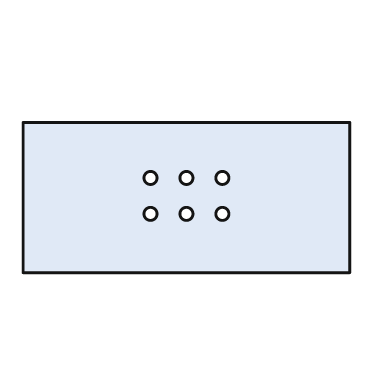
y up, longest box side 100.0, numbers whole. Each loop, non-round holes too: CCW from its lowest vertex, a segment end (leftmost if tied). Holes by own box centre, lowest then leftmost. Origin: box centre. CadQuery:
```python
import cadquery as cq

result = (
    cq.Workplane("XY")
    .moveTo(-50.0, -23.0)
    .lineTo(50.0, -23.0)
    .lineTo(50.0, 23.0)
    .lineTo(-50.0, 23.0)
    .close()
    .moveTo(-11.0, -5.0)
    .circle(2.0)
    .moveTo(0.0, -5.0)
    .circle(2.0)
    .moveTo(11.0, -5.0)
    .circle(2.0)
    .moveTo(-11.0, 6.0)
    .circle(2.0)
    .moveTo(0.0, 6.0)
    .circle(2.0)
    .moveTo(11.0, 6.0)
    .circle(2.0)
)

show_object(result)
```